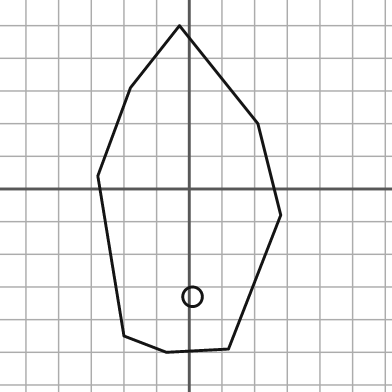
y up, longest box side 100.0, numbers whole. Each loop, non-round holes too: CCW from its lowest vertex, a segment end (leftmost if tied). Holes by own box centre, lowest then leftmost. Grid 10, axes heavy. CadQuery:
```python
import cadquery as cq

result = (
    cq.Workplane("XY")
    .moveTo(-7.0, -50.0)
    .lineTo(12.0, -49.0)
    .lineTo(28.0, -8.0)
    .lineTo(21.0, 20.0)
    .lineTo(-3.0, 50.0)
    .lineTo(-18.0, 31.0)
    .lineTo(-28.0, 4.0)
    .lineTo(-20.0, -45.0)
    .close()
    .moveTo(1.0, -33.0)
    .circle(3.0)
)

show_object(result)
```